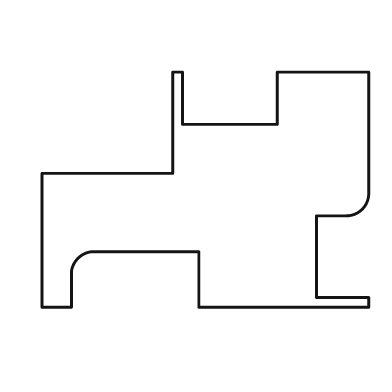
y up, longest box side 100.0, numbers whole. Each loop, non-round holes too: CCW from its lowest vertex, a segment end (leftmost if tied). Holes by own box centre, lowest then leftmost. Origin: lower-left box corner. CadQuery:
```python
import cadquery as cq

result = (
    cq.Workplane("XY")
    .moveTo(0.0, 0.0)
    .lineTo(9.0, 0.0)
    .lineTo(9.0, 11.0)
    .threePointArc((11.0, 15.0), (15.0, 17.0))
    .lineTo(48.0, 17.0)
    .lineTo(48.0, 0.0)
    .lineTo(100.0, 0.0)
    .lineTo(100.0, 3.0)
    .lineTo(84.0, 3.0)
    .lineTo(84.0, 28.0)
    .lineTo(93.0, 28.0)
    .threePointArc((98.0, 30.0), (100.0, 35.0))
    .lineTo(100.0, 72.0)
    .lineTo(72.0, 72.0)
    .lineTo(72.0, 56.0)
    .lineTo(43.0, 56.0)
    .lineTo(43.0, 72.0)
    .lineTo(40.0, 72.0)
    .lineTo(40.0, 41.0)
    .lineTo(0.0, 41.0)
    .close()
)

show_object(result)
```